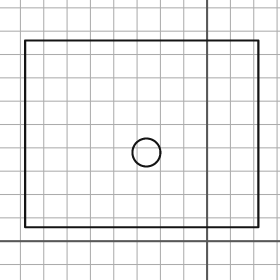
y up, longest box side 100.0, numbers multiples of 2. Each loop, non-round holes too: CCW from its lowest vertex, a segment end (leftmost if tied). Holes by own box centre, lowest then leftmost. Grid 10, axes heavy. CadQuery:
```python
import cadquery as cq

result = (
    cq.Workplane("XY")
    .moveTo(-78.0, 6.0)
    .lineTo(22.0, 6.0)
    .lineTo(22.0, 86.0)
    .lineTo(-78.0, 86.0)
    .close()
    .moveTo(-26.0, 38.0)
    .circle(6.0)
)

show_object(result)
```